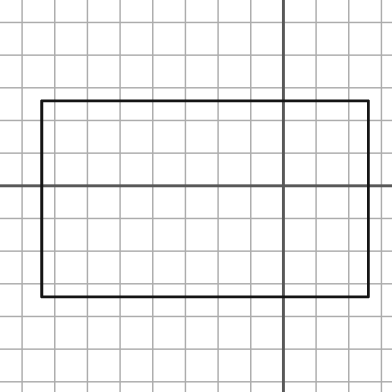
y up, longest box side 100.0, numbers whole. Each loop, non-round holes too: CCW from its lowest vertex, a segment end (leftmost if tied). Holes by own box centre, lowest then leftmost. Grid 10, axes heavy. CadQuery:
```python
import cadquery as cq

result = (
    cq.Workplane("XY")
    .moveTo(-74.0, -34.0)
    .lineTo(26.0, -34.0)
    .lineTo(26.0, 26.0)
    .lineTo(-74.0, 26.0)
    .close()
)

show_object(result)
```